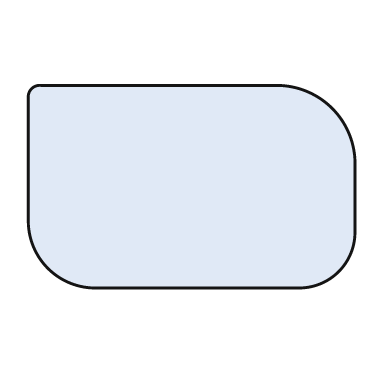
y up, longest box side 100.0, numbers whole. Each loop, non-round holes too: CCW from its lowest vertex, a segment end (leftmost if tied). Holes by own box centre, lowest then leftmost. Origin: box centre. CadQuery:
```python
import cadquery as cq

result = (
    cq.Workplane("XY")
    .moveTo(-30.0, -31.0)
    .lineTo(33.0, -31.0)
    .threePointArc((45.0, -26.0), (50.0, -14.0))
    .lineTo(50.0, 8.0)
    .threePointArc((43.0, 24.0), (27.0, 31.0))
    .lineTo(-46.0, 31.0)
    .threePointArc((-49.0, 30.0), (-50.0, 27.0))
    .lineTo(-50.0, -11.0)
    .threePointArc((-44.0, -25.0), (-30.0, -31.0))
    .close()
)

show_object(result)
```